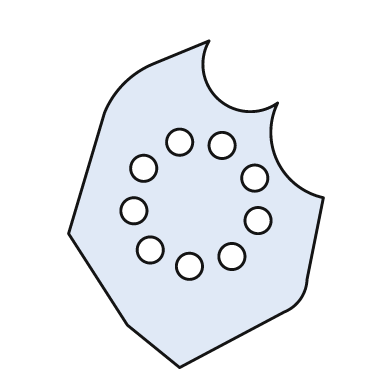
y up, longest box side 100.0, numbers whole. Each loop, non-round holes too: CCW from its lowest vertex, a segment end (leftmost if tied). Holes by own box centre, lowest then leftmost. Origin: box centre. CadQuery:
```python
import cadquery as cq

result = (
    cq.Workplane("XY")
    .moveTo(-5.0, -50.0)
    .lineTo(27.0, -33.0)
    .threePointArc((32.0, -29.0), (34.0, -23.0))
    .lineTo(39.0, 2.0)
    .threePointArc((25.0, 13.0), (25.0, 31.0))
    .threePointArc((7.0, 32.0), (4.0, 50.0))
    .lineTo(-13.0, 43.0)
    .threePointArc((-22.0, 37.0), (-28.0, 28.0))
    .lineTo(-39.0, -9.0)
    .lineTo(-21.0, -37.0)
    .close()
    .moveTo(-2.0, -19.0)
    .circle(4.0)
    .moveTo(11.0, -16.0)
    .circle(4.0)
    .moveTo(-14.0, -14.0)
    .circle(4.0)
    .moveTo(19.0, -5.0)
    .circle(4.0)
    .moveTo(-19.0, -2.0)
    .circle(4.0)
    .moveTo(18.0, 8.0)
    .circle(4.0)
    .moveTo(-16.0, 11.0)
    .circle(4.0)
    .moveTo(8.0, 18.0)
    .circle(4.0)
    .moveTo(-5.0, 19.0)
    .circle(4.0)
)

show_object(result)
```